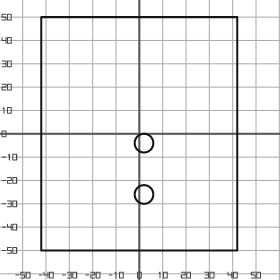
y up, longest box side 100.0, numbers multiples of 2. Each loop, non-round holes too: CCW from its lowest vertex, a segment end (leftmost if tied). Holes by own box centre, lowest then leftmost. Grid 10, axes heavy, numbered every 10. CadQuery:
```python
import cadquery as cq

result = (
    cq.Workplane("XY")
    .moveTo(-42.0, -50.0)
    .lineTo(42.0, -50.0)
    .lineTo(42.0, 50.0)
    .lineTo(-42.0, 50.0)
    .close()
    .moveTo(2.0, -26.0)
    .circle(4.0)
    .moveTo(2.0, -4.0)
    .circle(4.0)
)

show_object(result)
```